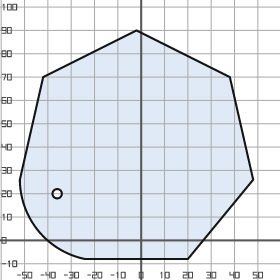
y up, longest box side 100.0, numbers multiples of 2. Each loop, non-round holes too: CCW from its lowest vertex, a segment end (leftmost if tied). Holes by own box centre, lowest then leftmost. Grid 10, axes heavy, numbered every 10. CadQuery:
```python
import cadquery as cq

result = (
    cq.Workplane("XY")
    .moveTo(-24.0, -8.0)
    .lineTo(20.0, -8.0)
    .lineTo(48.0, 26.0)
    .lineTo(38.0, 70.0)
    .lineTo(-2.0, 90.0)
    .lineTo(-42.0, 70.0)
    .lineTo(-52.0, 26.0)
    .threePointArc((-44.0, 4.0), (-24.0, -8.0))
    .close()
    .moveTo(-36.0, 20.0)
    .circle(2.0)
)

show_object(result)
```